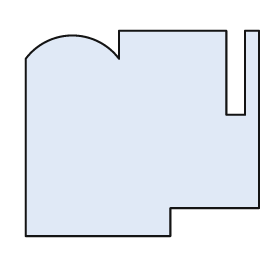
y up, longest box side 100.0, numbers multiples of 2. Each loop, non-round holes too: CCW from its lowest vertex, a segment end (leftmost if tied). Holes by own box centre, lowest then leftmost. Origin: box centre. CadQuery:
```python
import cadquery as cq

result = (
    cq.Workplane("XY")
    .moveTo(-50.0, -44.0)
    .lineTo(12.0, -44.0)
    .lineTo(12.0, -32.0)
    .lineTo(50.0, -32.0)
    .lineTo(50.0, 44.0)
    .lineTo(44.0, 44.0)
    .lineTo(44.0, 8.0)
    .lineTo(36.0, 8.0)
    .lineTo(36.0, 44.0)
    .lineTo(-10.0, 44.0)
    .lineTo(-10.0, 32.0)
    .threePointArc((-30.0, 42.0), (-50.0, 32.0))
    .close()
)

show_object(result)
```